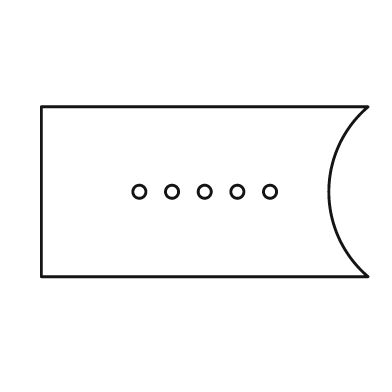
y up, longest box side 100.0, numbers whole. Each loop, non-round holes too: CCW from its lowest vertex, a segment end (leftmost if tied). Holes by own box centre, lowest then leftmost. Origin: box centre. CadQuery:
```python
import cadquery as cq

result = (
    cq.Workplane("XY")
    .moveTo(-50.0, -26.0)
    .lineTo(50.0, -26.0)
    .threePointArc((38.0, 0.0), (50.0, 26.0))
    .lineTo(-50.0, 26.0)
    .close()
    .moveTo(-20.0, 0.0)
    .circle(2.0)
    .moveTo(-10.0, 0.0)
    .circle(2.0)
    .moveTo(0.0, 0.0)
    .circle(2.0)
    .moveTo(10.0, 0.0)
    .circle(2.0)
    .moveTo(20.0, 0.0)
    .circle(2.0)
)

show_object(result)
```